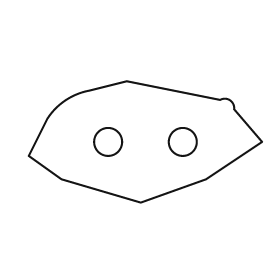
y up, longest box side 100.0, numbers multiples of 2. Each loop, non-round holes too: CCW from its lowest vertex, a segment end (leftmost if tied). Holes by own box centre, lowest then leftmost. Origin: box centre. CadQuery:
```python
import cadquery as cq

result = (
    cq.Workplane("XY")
    .moveTo(-2.0, -26.0)
    .lineTo(26.0, -16.0)
    .lineTo(50.0, 0.0)
    .lineTo(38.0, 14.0)
    .threePointArc((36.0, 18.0), (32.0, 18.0))
    .lineTo(-8.0, 26.0)
    .lineTo(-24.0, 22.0)
    .threePointArc((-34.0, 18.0), (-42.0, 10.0))
    .lineTo(-50.0, -6.0)
    .lineTo(-36.0, -16.0)
    .close()
    .moveTo(-16.0, 0.0)
    .circle(6.0)
    .moveTo(16.0, 0.0)
    .circle(6.0)
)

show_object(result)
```